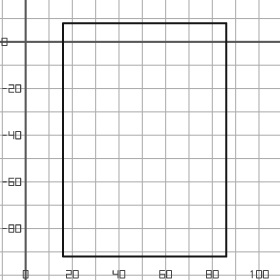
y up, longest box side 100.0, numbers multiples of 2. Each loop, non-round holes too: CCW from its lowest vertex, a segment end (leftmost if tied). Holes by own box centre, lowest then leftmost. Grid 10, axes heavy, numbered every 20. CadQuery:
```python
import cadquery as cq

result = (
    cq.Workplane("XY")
    .moveTo(16.0, -92.0)
    .lineTo(86.0, -92.0)
    .lineTo(86.0, 8.0)
    .lineTo(16.0, 8.0)
    .close()
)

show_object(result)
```